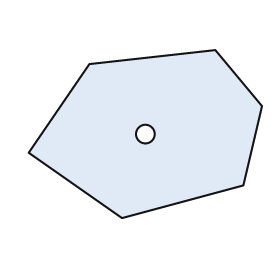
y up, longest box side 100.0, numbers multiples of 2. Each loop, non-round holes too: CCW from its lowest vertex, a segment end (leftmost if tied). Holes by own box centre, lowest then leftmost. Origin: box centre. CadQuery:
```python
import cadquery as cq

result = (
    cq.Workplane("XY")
    .moveTo(-10.0, -36.0)
    .lineTo(42.0, -22.0)
    .lineTo(50.0, 12.0)
    .lineTo(30.0, 36.0)
    .lineTo(-24.0, 30.0)
    .lineTo(-50.0, -8.0)
    .close()
    .moveTo(0.0, 0.0)
    .circle(4.0)
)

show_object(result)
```